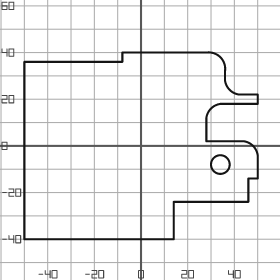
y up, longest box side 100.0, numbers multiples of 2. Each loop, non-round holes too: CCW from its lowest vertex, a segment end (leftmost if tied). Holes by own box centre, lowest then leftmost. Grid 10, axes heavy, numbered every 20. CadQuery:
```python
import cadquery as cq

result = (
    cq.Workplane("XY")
    .moveTo(-50.0, -40.0)
    .lineTo(14.0, -40.0)
    .lineTo(14.0, -24.0)
    .lineTo(46.0, -24.0)
    .lineTo(46.0, -14.0)
    .lineTo(50.0, -14.0)
    .lineTo(50.0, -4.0)
    .threePointArc((48.0, 0.0), (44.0, 2.0))
    .lineTo(28.0, 2.0)
    .lineTo(28.0, 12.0)
    .threePointArc((30.0, 16.0), (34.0, 18.0))
    .lineTo(50.0, 18.0)
    .lineTo(50.0, 22.0)
    .lineTo(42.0, 22.0)
    .threePointArc((38.0, 24.0), (36.0, 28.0))
    .lineTo(36.0, 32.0)
    .threePointArc((34.0, 38.0), (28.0, 40.0))
    .lineTo(-8.0, 40.0)
    .lineTo(-8.0, 36.0)
    .lineTo(-50.0, 36.0)
    .close()
    .moveTo(34.0, -8.0)
    .circle(4.0)
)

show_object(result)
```